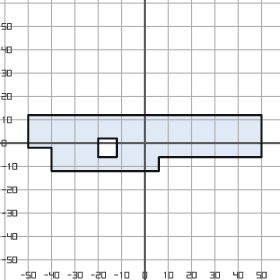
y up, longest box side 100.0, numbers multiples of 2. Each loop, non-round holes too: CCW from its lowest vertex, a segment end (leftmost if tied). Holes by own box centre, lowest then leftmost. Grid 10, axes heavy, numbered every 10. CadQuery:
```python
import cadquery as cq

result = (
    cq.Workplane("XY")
    .moveTo(-40.0, -12.0)
    .lineTo(6.0, -12.0)
    .lineTo(6.0, -6.0)
    .lineTo(50.0, -6.0)
    .lineTo(50.0, 12.0)
    .lineTo(-50.0, 12.0)
    .lineTo(-50.0, -2.0)
    .lineTo(-40.0, -2.0)
    .close()
    .moveTo(-20.0, -6.0)
    .lineTo(-12.0, -6.0)
    .lineTo(-12.0, 2.0)
    .lineTo(-20.0, 2.0)
    .close()
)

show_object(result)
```